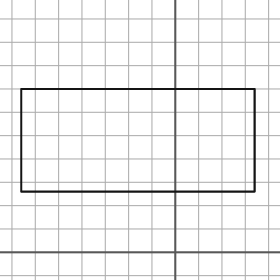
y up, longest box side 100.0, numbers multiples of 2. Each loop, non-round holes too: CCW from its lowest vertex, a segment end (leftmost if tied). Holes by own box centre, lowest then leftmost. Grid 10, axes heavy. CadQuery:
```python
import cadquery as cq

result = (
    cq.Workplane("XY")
    .moveTo(-66.0, 26.0)
    .lineTo(34.0, 26.0)
    .lineTo(34.0, 70.0)
    .lineTo(-66.0, 70.0)
    .close()
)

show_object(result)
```